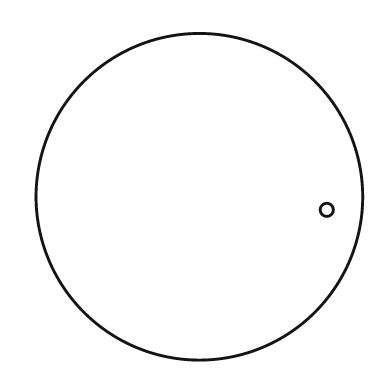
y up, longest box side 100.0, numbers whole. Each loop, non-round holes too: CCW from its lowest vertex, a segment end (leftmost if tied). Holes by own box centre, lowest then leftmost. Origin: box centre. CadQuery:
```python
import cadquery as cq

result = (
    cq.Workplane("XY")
    .moveTo(0.0, 0.0)
    .circle(50.0)
    .moveTo(39.0, -4.0)
    .circle(2.0)
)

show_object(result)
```